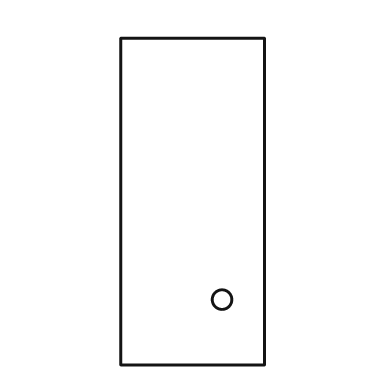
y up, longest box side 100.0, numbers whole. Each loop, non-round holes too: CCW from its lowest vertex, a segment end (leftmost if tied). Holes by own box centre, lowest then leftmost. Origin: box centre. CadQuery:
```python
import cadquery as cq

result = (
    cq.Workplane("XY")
    .moveTo(-22.0, -50.0)
    .lineTo(22.0, -50.0)
    .lineTo(22.0, 50.0)
    .lineTo(-22.0, 50.0)
    .close()
    .moveTo(9.0, -30.0)
    .circle(3.0)
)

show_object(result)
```